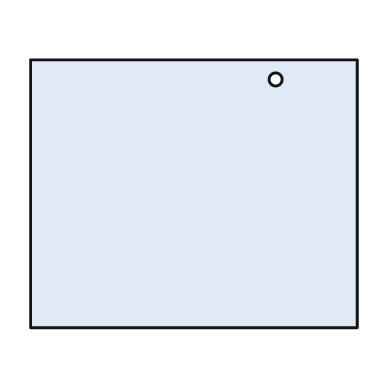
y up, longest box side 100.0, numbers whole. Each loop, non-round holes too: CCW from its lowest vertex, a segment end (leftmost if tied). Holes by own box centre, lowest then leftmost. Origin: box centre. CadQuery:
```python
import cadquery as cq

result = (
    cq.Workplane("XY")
    .moveTo(-50.0, -41.0)
    .lineTo(50.0, -41.0)
    .lineTo(50.0, 41.0)
    .lineTo(-50.0, 41.0)
    .close()
    .moveTo(25.0, 35.0)
    .circle(2.0)
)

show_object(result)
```